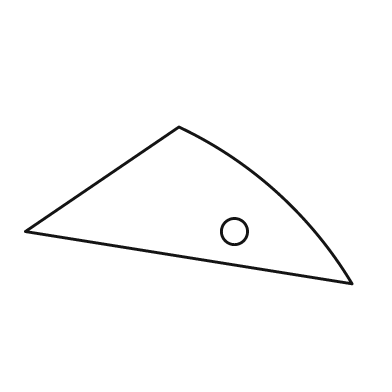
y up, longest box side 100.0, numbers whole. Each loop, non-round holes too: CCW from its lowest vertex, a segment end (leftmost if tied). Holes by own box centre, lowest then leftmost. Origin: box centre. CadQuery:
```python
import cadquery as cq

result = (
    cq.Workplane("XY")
    .moveTo(50.0, -24.0)
    .threePointArc((27.0, 4.0), (-3.0, 24.0))
    .lineTo(-50.0, -8.0)
    .close()
    .moveTo(14.0, -8.0)
    .circle(4.0)
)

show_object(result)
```